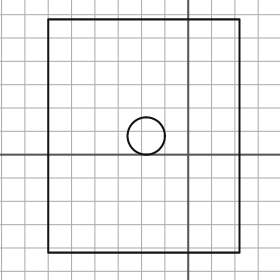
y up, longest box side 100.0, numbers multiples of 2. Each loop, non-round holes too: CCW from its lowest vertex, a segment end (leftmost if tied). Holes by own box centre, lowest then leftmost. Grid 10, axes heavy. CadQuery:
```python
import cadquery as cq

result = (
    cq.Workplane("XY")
    .moveTo(-60.0, -42.0)
    .lineTo(22.0, -42.0)
    .lineTo(22.0, 58.0)
    .lineTo(-60.0, 58.0)
    .close()
    .moveTo(-18.0, 8.0)
    .circle(8.0)
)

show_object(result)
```